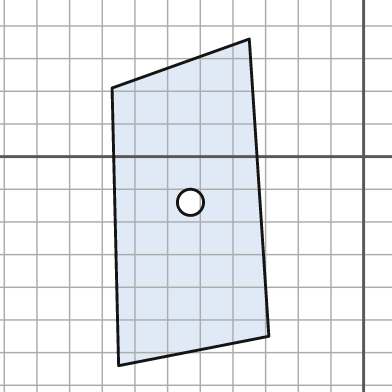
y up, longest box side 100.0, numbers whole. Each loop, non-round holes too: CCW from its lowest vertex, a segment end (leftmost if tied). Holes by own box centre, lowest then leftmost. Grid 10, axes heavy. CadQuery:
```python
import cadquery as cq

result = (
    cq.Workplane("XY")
    .moveTo(-75.0, -64.0)
    .lineTo(-29.0, -55.0)
    .lineTo(-35.0, 36.0)
    .lineTo(-77.0, 21.0)
    .close()
    .moveTo(-53.0, -14.0)
    .circle(4.0)
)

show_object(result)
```